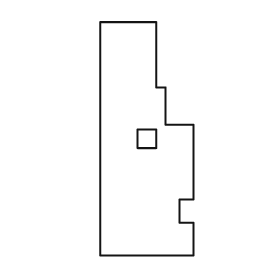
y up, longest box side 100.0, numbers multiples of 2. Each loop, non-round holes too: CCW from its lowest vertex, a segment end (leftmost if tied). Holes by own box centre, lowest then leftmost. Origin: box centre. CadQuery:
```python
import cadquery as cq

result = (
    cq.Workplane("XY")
    .moveTo(-20.0, -50.0)
    .lineTo(20.0, -50.0)
    .lineTo(20.0, -36.0)
    .lineTo(14.0, -36.0)
    .lineTo(14.0, -26.0)
    .lineTo(20.0, -26.0)
    .lineTo(20.0, 6.0)
    .lineTo(8.0, 6.0)
    .lineTo(8.0, 22.0)
    .lineTo(4.0, 22.0)
    .lineTo(4.0, 50.0)
    .lineTo(-20.0, 50.0)
    .close()
    .moveTo(-4.0, -4.0)
    .lineTo(4.0, -4.0)
    .lineTo(4.0, 4.0)
    .lineTo(-4.0, 4.0)
    .close()
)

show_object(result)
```